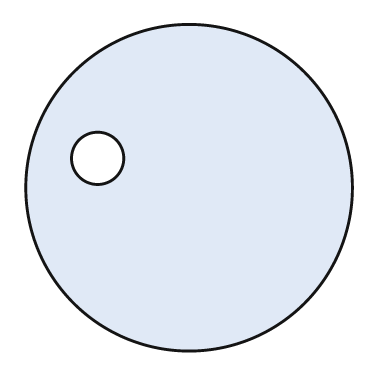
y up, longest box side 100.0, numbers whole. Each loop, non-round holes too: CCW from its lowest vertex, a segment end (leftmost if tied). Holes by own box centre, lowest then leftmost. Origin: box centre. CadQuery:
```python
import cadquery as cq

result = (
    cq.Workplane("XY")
    .moveTo(0.0, 0.0)
    .circle(50.0)
    .moveTo(-28.0, 9.0)
    .circle(8.0)
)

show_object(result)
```